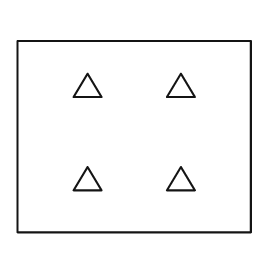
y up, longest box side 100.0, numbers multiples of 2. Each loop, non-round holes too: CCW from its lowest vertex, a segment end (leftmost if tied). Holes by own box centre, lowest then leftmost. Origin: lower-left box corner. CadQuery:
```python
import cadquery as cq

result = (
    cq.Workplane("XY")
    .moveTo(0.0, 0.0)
    .lineTo(100.0, 0.0)
    .lineTo(100.0, 82.0)
    .lineTo(0.0, 82.0)
    .close()
    .moveTo(24.0, 18.0)
    .lineTo(36.0, 18.0)
    .lineTo(30.0, 28.0)
    .close()
    .moveTo(64.0, 18.0)
    .lineTo(76.0, 18.0)
    .lineTo(70.0, 28.0)
    .close()
    .moveTo(24.0, 58.0)
    .lineTo(36.0, 58.0)
    .lineTo(30.0, 68.0)
    .close()
    .moveTo(64.0, 58.0)
    .lineTo(76.0, 58.0)
    .lineTo(70.0, 68.0)
    .close()
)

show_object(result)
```